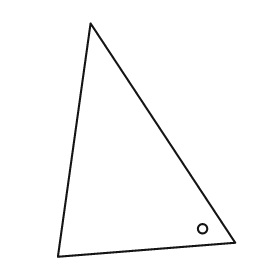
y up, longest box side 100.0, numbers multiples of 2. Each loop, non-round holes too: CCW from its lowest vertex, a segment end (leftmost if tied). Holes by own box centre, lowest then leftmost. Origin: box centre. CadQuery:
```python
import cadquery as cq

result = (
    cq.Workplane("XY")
    .moveTo(-38.0, -50.0)
    .lineTo(38.0, -44.0)
    .lineTo(-24.0, 50.0)
    .close()
    .moveTo(24.0, -38.0)
    .circle(2.0)
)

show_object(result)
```